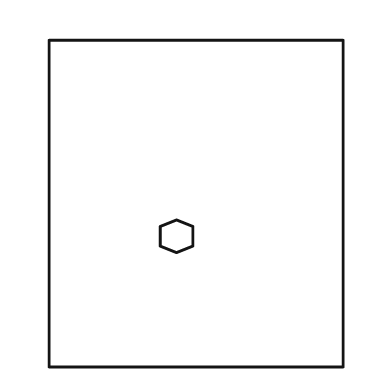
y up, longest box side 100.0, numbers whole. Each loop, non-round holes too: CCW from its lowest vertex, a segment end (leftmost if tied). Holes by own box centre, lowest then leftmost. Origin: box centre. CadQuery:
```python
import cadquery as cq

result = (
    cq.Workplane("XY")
    .moveTo(-45.0, -50.0)
    .lineTo(45.0, -50.0)
    .lineTo(45.0, 50.0)
    .lineTo(-45.0, 50.0)
    .close()
    .moveTo(-6.0, -15.0)
    .lineTo(-1.0, -13.0)
    .lineTo(-1.0, -7.0)
    .lineTo(-6.0, -5.0)
    .lineTo(-11.0, -7.0)
    .lineTo(-11.0, -13.0)
    .close()
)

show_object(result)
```